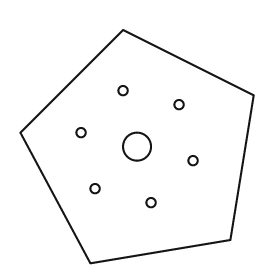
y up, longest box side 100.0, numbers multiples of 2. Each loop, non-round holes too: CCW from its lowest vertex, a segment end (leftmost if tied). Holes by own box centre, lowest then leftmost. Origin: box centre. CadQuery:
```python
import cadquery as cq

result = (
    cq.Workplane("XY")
    .moveTo(-20.0, -50.0)
    .lineTo(40.0, -40.0)
    .lineTo(50.0, 22.0)
    .lineTo(-6.0, 50.0)
    .lineTo(-50.0, 6.0)
    .close()
    .moveTo(6.0, -24.0)
    .circle(2.0)
    .moveTo(-18.0, -18.0)
    .circle(2.0)
    .moveTo(24.0, -6.0)
    .circle(2.0)
    .moveTo(0.0, 0.0)
    .circle(6.0)
    .moveTo(-24.0, 6.0)
    .circle(2.0)
    .moveTo(18.0, 18.0)
    .circle(2.0)
    .moveTo(-6.0, 24.0)
    .circle(2.0)
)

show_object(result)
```